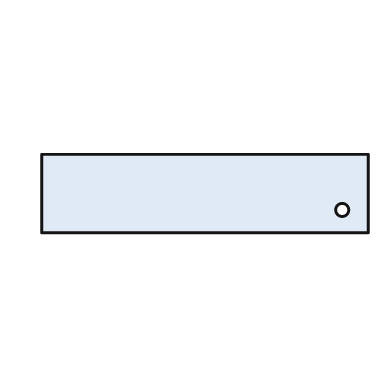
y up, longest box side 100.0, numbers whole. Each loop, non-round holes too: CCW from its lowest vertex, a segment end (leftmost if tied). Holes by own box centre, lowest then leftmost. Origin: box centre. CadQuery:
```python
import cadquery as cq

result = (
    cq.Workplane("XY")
    .moveTo(-50.0, -12.0)
    .lineTo(50.0, -12.0)
    .lineTo(50.0, 12.0)
    .lineTo(-50.0, 12.0)
    .close()
    .moveTo(42.0, -5.0)
    .circle(2.0)
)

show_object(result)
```